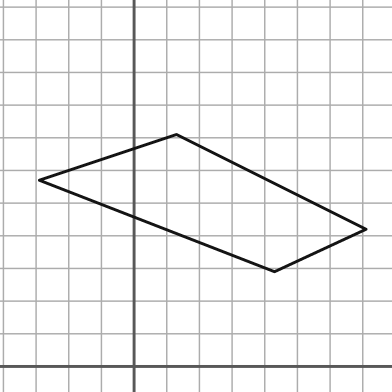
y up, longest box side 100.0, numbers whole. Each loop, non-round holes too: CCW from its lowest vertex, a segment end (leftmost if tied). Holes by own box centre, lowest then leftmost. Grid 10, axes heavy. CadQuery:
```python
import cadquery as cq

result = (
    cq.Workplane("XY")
    .moveTo(43.0, 29.0)
    .lineTo(71.0, 42.0)
    .lineTo(13.0, 71.0)
    .lineTo(-29.0, 57.0)
    .close()
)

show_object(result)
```